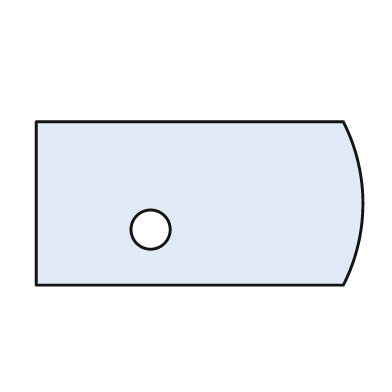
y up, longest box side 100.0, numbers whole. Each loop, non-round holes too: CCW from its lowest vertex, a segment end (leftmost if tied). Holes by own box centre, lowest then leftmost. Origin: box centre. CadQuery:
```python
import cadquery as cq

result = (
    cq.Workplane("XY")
    .moveTo(-50.0, -25.0)
    .lineTo(44.0, -25.0)
    .threePointArc((50.0, 0.0), (44.0, 25.0))
    .lineTo(-50.0, 25.0)
    .close()
    .moveTo(-15.0, -8.0)
    .circle(6.0)
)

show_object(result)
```